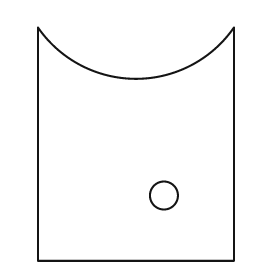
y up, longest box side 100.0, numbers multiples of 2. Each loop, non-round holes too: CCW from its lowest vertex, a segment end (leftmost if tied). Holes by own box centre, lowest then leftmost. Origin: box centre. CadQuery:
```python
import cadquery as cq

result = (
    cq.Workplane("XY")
    .moveTo(-42.0, -50.0)
    .lineTo(42.0, -50.0)
    .lineTo(42.0, 50.0)
    .threePointArc((0.0, 28.0), (-42.0, 50.0))
    .close()
    .moveTo(12.0, -22.0)
    .circle(6.0)
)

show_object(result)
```